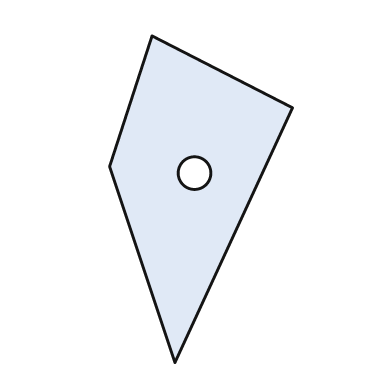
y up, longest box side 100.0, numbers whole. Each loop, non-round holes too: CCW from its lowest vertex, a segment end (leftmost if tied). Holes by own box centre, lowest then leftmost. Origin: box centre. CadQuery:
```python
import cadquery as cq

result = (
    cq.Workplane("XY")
    .moveTo(-8.0, -50.0)
    .lineTo(28.0, 28.0)
    .lineTo(-15.0, 50.0)
    .lineTo(-28.0, 10.0)
    .close()
    .moveTo(-2.0, 8.0)
    .circle(5.0)
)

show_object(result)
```